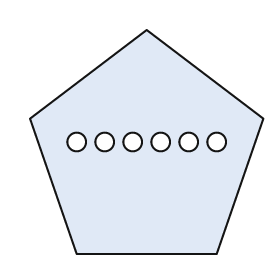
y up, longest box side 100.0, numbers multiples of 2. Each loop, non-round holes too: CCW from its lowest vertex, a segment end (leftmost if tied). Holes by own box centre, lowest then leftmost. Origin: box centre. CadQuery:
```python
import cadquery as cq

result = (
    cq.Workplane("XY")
    .moveTo(-30.0, -48.0)
    .lineTo(30.0, -48.0)
    .lineTo(50.0, 10.0)
    .lineTo(0.0, 48.0)
    .lineTo(-50.0, 10.0)
    .close()
    .moveTo(-30.0, 0.0)
    .circle(4.0)
    .moveTo(-18.0, 0.0)
    .circle(4.0)
    .moveTo(-6.0, 0.0)
    .circle(4.0)
    .moveTo(6.0, 0.0)
    .circle(4.0)
    .moveTo(18.0, 0.0)
    .circle(4.0)
    .moveTo(30.0, 0.0)
    .circle(4.0)
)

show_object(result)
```